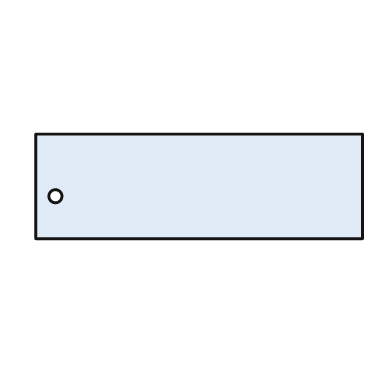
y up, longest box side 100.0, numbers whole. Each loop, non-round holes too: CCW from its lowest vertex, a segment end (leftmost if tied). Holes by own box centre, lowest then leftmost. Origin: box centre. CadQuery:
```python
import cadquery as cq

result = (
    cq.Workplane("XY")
    .moveTo(-50.0, -16.0)
    .lineTo(50.0, -16.0)
    .lineTo(50.0, 16.0)
    .lineTo(-50.0, 16.0)
    .close()
    .moveTo(-44.0, -3.0)
    .circle(2.0)
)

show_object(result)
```